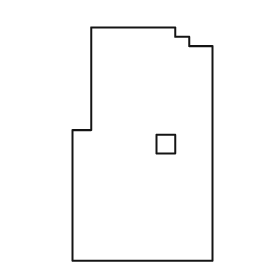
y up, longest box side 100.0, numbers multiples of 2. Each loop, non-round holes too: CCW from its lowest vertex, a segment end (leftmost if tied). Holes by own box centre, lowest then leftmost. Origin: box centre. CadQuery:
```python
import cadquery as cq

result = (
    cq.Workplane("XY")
    .moveTo(-30.0, -50.0)
    .lineTo(30.0, -50.0)
    .lineTo(30.0, 42.0)
    .lineTo(20.0, 42.0)
    .lineTo(20.0, 46.0)
    .lineTo(14.0, 46.0)
    .lineTo(14.0, 50.0)
    .lineTo(-22.0, 50.0)
    .lineTo(-22.0, 6.0)
    .lineTo(-30.0, 6.0)
    .close()
    .moveTo(6.0, -4.0)
    .lineTo(14.0, -4.0)
    .lineTo(14.0, 4.0)
    .lineTo(6.0, 4.0)
    .close()
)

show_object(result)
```